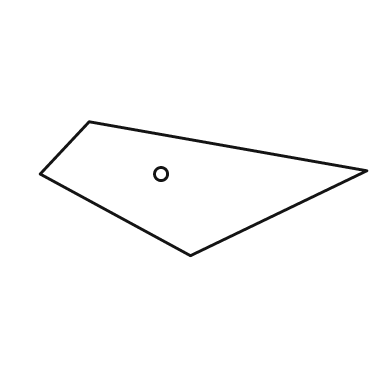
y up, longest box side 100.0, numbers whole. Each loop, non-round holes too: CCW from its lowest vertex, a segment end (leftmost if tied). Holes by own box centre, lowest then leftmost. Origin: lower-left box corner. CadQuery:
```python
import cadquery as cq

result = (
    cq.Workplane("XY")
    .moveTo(46.0, 0.0)
    .lineTo(100.0, 26.0)
    .lineTo(15.0, 41.0)
    .lineTo(0.0, 25.0)
    .close()
    .moveTo(37.0, 25.0)
    .circle(2.0)
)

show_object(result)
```